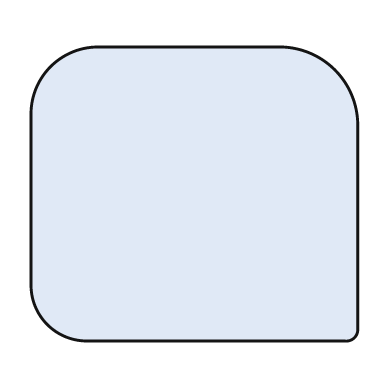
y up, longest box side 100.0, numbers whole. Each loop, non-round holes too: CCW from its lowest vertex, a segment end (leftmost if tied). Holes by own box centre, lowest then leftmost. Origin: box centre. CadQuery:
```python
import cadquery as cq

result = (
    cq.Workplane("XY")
    .moveTo(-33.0, -45.0)
    .lineTo(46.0, -45.0)
    .threePointArc((49.0, -44.0), (50.0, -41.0))
    .lineTo(50.0, 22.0)
    .threePointArc((43.0, 38.0), (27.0, 45.0))
    .lineTo(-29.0, 45.0)
    .threePointArc((-44.0, 39.0), (-50.0, 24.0))
    .lineTo(-50.0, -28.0)
    .threePointArc((-45.0, -40.0), (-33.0, -45.0))
    .close()
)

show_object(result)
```